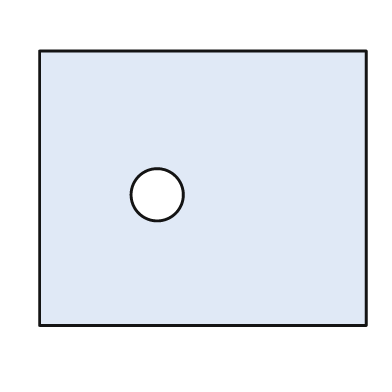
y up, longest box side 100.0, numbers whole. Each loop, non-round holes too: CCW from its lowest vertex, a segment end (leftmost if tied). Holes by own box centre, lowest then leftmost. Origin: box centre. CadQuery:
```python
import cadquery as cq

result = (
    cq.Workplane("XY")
    .moveTo(-50.0, -42.0)
    .lineTo(50.0, -42.0)
    .lineTo(50.0, 42.0)
    .lineTo(-50.0, 42.0)
    .close()
    .moveTo(-14.0, -2.0)
    .circle(8.0)
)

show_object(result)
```